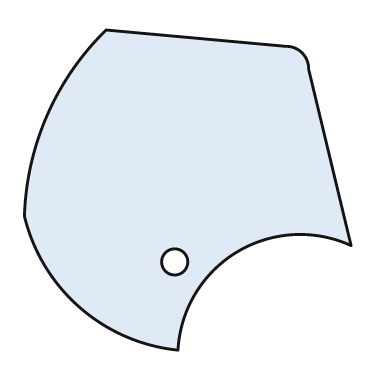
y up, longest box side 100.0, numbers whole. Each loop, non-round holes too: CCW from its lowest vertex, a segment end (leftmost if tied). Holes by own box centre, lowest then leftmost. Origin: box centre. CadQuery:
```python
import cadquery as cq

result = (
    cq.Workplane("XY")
    .moveTo(-3.0, -49.0)
    .threePointArc((15.0, -19.0), (50.0, -17.0))
    .lineTo(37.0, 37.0)
    .threePointArc((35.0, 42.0), (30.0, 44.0))
    .lineTo(-25.0, 49.0)
    .threePointArc((-43.0, 23.0), (-50.0, -8.0))
    .threePointArc((-33.0, -36.0), (-3.0, -49.0))
    .close()
    .moveTo(-4.0, -22.0)
    .circle(4.0)
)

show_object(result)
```